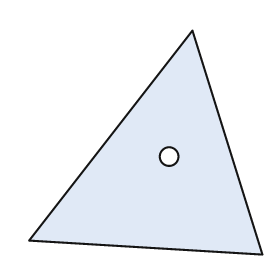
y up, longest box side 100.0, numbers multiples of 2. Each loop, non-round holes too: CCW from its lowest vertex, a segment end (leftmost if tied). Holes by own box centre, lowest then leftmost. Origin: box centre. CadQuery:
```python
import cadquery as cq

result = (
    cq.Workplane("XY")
    .moveTo(50.0, -48.0)
    .lineTo(20.0, 48.0)
    .lineTo(-50.0, -42.0)
    .close()
    .moveTo(10.0, -6.0)
    .circle(4.0)
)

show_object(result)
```